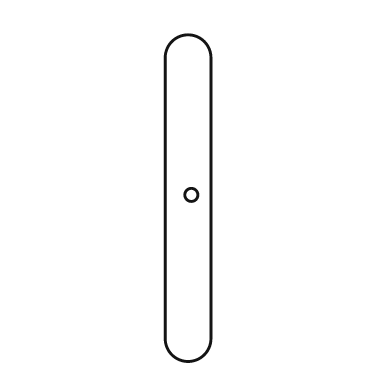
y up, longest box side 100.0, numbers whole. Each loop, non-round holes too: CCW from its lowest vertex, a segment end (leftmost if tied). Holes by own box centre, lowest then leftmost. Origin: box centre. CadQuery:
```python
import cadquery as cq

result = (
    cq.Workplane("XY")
    .moveTo(-7.0, -43.0)
    .threePointArc((0.0, -50.0), (7.0, -43.0))
    .lineTo(7.0, 43.0)
    .threePointArc((0.0, 50.0), (-7.0, 43.0))
    .close()
    .moveTo(1.0, 1.0)
    .circle(2.0)
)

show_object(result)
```